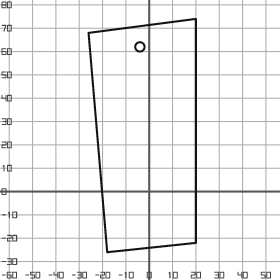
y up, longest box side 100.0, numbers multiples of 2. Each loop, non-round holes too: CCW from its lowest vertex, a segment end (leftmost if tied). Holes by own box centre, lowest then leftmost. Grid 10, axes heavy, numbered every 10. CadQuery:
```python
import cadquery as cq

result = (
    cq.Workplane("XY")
    .moveTo(-18.0, -26.0)
    .lineTo(20.0, -22.0)
    .lineTo(20.0, 74.0)
    .lineTo(-26.0, 68.0)
    .close()
    .moveTo(-4.0, 62.0)
    .circle(2.0)
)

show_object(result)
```